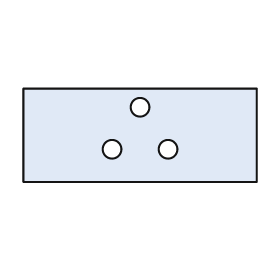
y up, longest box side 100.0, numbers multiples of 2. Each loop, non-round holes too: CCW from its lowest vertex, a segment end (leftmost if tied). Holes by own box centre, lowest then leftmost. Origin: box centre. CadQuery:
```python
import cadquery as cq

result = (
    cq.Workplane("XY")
    .moveTo(-50.0, -20.0)
    .lineTo(50.0, -20.0)
    .lineTo(50.0, 20.0)
    .lineTo(-50.0, 20.0)
    .close()
    .moveTo(-12.0, -6.0)
    .circle(4.0)
    .moveTo(12.0, -6.0)
    .circle(4.0)
    .moveTo(0.0, 12.0)
    .circle(4.0)
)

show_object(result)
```